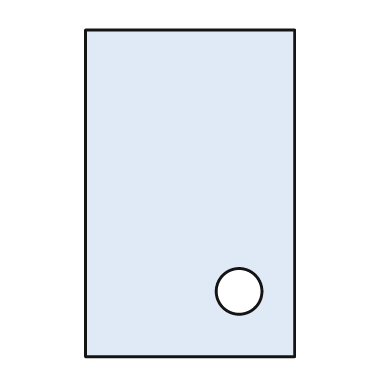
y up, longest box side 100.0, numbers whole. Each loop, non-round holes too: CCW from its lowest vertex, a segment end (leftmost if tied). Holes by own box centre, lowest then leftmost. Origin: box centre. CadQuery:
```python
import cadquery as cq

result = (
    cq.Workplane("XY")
    .moveTo(-32.0, -50.0)
    .lineTo(32.0, -50.0)
    .lineTo(32.0, 50.0)
    .lineTo(-32.0, 50.0)
    .close()
    .moveTo(15.0, -30.0)
    .circle(7.0)
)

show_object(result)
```